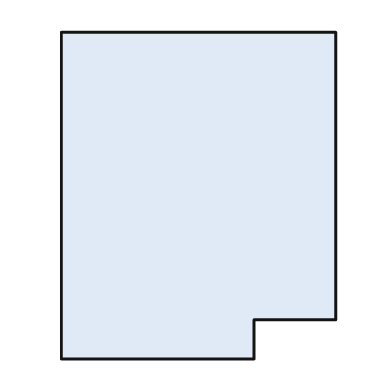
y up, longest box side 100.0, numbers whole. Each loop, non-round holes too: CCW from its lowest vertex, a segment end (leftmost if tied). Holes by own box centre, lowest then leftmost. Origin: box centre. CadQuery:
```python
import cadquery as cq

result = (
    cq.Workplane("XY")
    .moveTo(-42.0, -50.0)
    .lineTo(17.0, -50.0)
    .lineTo(17.0, -38.0)
    .lineTo(42.0, -38.0)
    .lineTo(42.0, 50.0)
    .lineTo(-42.0, 50.0)
    .close()
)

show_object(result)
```